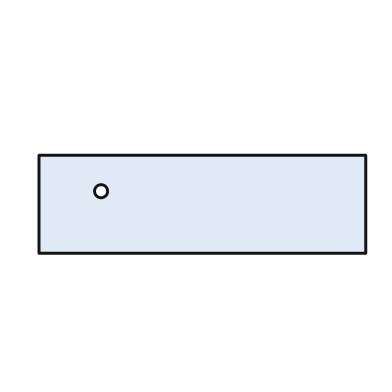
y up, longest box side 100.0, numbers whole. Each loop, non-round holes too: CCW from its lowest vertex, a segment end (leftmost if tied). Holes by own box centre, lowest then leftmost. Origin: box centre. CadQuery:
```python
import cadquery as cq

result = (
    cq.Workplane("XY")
    .moveTo(-50.0, -15.0)
    .lineTo(50.0, -15.0)
    .lineTo(50.0, 15.0)
    .lineTo(-50.0, 15.0)
    .close()
    .moveTo(-31.0, 4.0)
    .circle(2.0)
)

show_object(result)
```